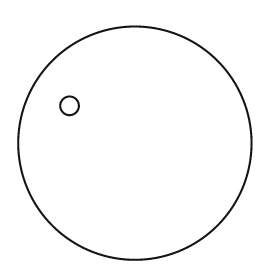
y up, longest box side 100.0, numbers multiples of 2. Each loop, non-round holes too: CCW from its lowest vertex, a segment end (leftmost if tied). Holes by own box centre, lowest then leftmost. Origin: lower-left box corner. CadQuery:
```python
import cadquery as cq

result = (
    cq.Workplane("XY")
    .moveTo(50.0, 50.0)
    .circle(50.0)
    .moveTo(22.0, 66.0)
    .circle(4.0)
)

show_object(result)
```